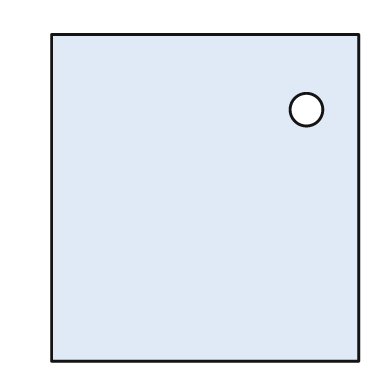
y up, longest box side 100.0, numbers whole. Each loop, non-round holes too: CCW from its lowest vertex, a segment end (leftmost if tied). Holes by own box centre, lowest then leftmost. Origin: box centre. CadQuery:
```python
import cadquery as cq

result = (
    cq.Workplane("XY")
    .moveTo(-47.0, -50.0)
    .lineTo(47.0, -50.0)
    .lineTo(47.0, 50.0)
    .lineTo(-47.0, 50.0)
    .close()
    .moveTo(31.0, 27.0)
    .circle(5.0)
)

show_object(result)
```